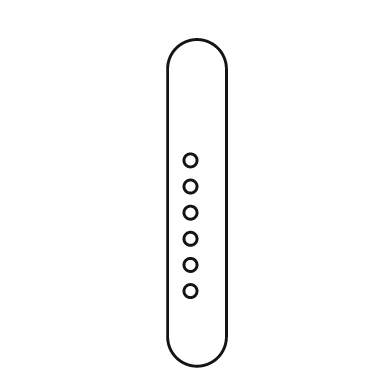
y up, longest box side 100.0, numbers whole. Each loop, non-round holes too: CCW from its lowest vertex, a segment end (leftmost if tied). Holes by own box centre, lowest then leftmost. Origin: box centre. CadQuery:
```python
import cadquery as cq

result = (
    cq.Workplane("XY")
    .moveTo(-9.0, -41.0)
    .threePointArc((0.0, -50.0), (9.0, -41.0))
    .lineTo(9.0, 41.0)
    .threePointArc((0.0, 50.0), (-9.0, 41.0))
    .close()
    .moveTo(-2.0, -27.0)
    .circle(2.0)
    .moveTo(-2.0, -19.0)
    .circle(2.0)
    .moveTo(-2.0, -11.0)
    .circle(2.0)
    .moveTo(-2.0, -3.0)
    .circle(2.0)
    .moveTo(-2.0, 5.0)
    .circle(2.0)
    .moveTo(-2.0, 13.0)
    .circle(2.0)
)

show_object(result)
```